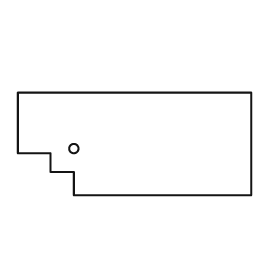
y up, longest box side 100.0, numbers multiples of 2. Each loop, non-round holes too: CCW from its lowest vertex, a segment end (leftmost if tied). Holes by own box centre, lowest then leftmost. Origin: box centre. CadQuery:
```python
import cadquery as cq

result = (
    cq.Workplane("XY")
    .moveTo(-26.0, -22.0)
    .lineTo(50.0, -22.0)
    .lineTo(50.0, 22.0)
    .lineTo(-50.0, 22.0)
    .lineTo(-50.0, -4.0)
    .lineTo(-36.0, -4.0)
    .lineTo(-36.0, -12.0)
    .lineTo(-26.0, -12.0)
    .close()
    .moveTo(-26.0, -2.0)
    .circle(2.0)
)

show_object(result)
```